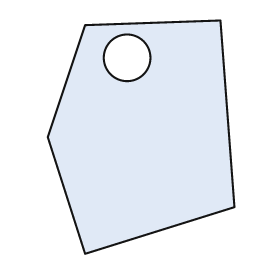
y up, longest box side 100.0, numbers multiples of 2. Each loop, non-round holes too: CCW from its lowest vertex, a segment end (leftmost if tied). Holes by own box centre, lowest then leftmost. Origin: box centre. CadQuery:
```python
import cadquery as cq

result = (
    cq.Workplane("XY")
    .moveTo(-24.0, -50.0)
    .lineTo(40.0, -30.0)
    .lineTo(34.0, 50.0)
    .lineTo(-24.0, 48.0)
    .lineTo(-40.0, 0.0)
    .close()
    .moveTo(-6.0, 34.0)
    .circle(10.0)
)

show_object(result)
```